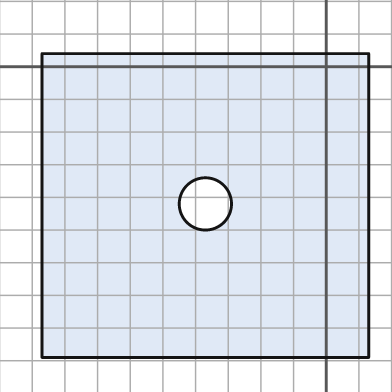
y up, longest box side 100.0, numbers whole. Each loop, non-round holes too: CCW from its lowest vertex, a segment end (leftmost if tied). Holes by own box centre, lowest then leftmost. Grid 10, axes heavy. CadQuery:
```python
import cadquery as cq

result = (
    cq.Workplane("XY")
    .moveTo(-87.0, -89.0)
    .lineTo(13.0, -89.0)
    .lineTo(13.0, 4.0)
    .lineTo(-87.0, 4.0)
    .close()
    .moveTo(-37.0, -42.0)
    .circle(8.0)
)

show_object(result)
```